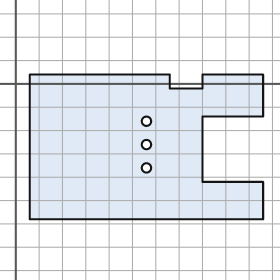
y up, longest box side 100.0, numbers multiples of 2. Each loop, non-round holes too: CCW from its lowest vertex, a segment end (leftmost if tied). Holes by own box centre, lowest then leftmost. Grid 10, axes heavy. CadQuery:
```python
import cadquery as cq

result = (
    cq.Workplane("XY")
    .moveTo(6.0, -58.0)
    .lineTo(106.0, -58.0)
    .lineTo(106.0, -42.0)
    .lineTo(80.0, -42.0)
    .lineTo(80.0, -14.0)
    .lineTo(106.0, -14.0)
    .lineTo(106.0, 4.0)
    .lineTo(80.0, 4.0)
    .lineTo(80.0, -2.0)
    .lineTo(66.0, -2.0)
    .lineTo(66.0, 4.0)
    .lineTo(6.0, 4.0)
    .close()
    .moveTo(56.0, -36.0)
    .circle(2.0)
    .moveTo(56.0, -26.0)
    .circle(2.0)
    .moveTo(56.0, -16.0)
    .circle(2.0)
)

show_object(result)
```